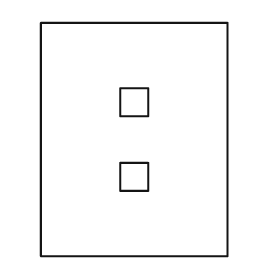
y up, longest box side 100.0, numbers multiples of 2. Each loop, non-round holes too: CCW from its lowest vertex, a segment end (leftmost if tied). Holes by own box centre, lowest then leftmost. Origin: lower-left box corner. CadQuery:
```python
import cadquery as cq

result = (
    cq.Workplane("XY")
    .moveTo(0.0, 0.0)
    .lineTo(80.0, 0.0)
    .lineTo(80.0, 100.0)
    .lineTo(0.0, 100.0)
    .close()
    .moveTo(34.0, 28.0)
    .lineTo(46.0, 28.0)
    .lineTo(46.0, 40.0)
    .lineTo(34.0, 40.0)
    .close()
    .moveTo(34.0, 60.0)
    .lineTo(46.0, 60.0)
    .lineTo(46.0, 72.0)
    .lineTo(34.0, 72.0)
    .close()
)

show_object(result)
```